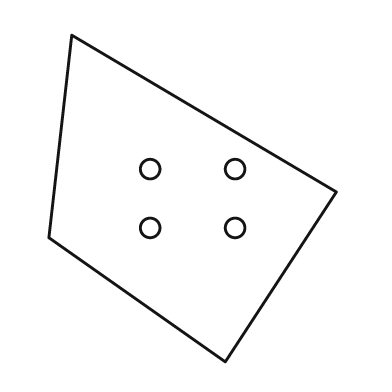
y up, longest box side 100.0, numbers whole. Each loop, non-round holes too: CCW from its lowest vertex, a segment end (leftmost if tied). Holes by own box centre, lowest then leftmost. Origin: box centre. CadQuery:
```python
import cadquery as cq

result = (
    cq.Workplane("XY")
    .moveTo(10.0, -50.0)
    .lineTo(44.0, 2.0)
    .lineTo(-37.0, 50.0)
    .lineTo(-44.0, -12.0)
    .close()
    .moveTo(-13.0, -9.0)
    .circle(3.0)
    .moveTo(13.0, -9.0)
    .circle(3.0)
    .moveTo(-13.0, 9.0)
    .circle(3.0)
    .moveTo(13.0, 9.0)
    .circle(3.0)
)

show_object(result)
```